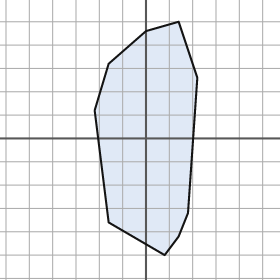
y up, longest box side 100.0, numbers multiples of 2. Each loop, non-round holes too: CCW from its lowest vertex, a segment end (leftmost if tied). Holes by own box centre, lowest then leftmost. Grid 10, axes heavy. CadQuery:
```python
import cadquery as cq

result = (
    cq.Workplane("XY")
    .moveTo(8.0, -50.0)
    .lineTo(14.0, -42.0)
    .lineTo(18.0, -32.0)
    .lineTo(22.0, 26.0)
    .lineTo(14.0, 50.0)
    .lineTo(0.0, 46.0)
    .lineTo(-16.0, 32.0)
    .lineTo(-22.0, 12.0)
    .lineTo(-16.0, -36.0)
    .close()
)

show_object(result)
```